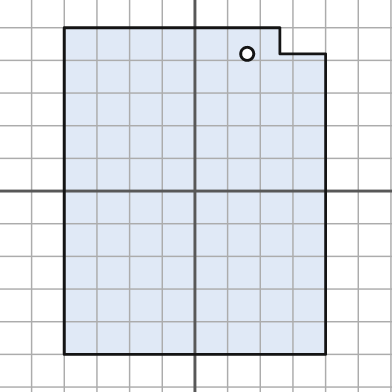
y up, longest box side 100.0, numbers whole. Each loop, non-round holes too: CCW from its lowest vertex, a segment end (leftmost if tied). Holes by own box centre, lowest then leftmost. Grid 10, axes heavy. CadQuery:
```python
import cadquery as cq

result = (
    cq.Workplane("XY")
    .moveTo(-40.0, -50.0)
    .lineTo(40.0, -50.0)
    .lineTo(40.0, 42.0)
    .lineTo(26.0, 42.0)
    .lineTo(26.0, 50.0)
    .lineTo(-40.0, 50.0)
    .close()
    .moveTo(16.0, 42.0)
    .circle(2.0)
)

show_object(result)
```